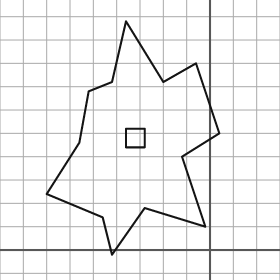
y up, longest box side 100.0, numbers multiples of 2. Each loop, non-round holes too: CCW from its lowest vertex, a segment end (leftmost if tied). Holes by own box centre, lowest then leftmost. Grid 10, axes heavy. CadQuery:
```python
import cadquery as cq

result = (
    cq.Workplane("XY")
    .moveTo(-42.0, -2.0)
    .lineTo(-28.0, 18.0)
    .lineTo(-2.0, 10.0)
    .lineTo(-12.0, 40.0)
    .lineTo(4.0, 50.0)
    .lineTo(-6.0, 80.0)
    .lineTo(-20.0, 72.0)
    .lineTo(-36.0, 98.0)
    .lineTo(-42.0, 72.0)
    .lineTo(-52.0, 68.0)
    .lineTo(-56.0, 46.0)
    .lineTo(-70.0, 24.0)
    .lineTo(-46.0, 14.0)
    .close()
    .moveTo(-36.0, 44.0)
    .lineTo(-28.0, 44.0)
    .lineTo(-28.0, 52.0)
    .lineTo(-36.0, 52.0)
    .close()
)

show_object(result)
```